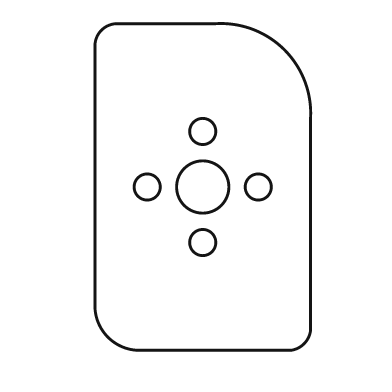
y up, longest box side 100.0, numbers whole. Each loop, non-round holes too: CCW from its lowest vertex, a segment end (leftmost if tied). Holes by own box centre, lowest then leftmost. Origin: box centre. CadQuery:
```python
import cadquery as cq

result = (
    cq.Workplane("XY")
    .moveTo(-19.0, -50.0)
    .lineTo(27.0, -50.0)
    .threePointArc((31.0, -48.0), (33.0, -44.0))
    .lineTo(33.0, 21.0)
    .threePointArc((25.0, 42.0), (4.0, 50.0))
    .lineTo(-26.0, 50.0)
    .threePointArc((-31.0, 48.0), (-33.0, 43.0))
    .lineTo(-33.0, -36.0)
    .threePointArc((-29.0, -46.0), (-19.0, -50.0))
    .close()
    .moveTo(0.0, -17.0)
    .circle(4.0)
    .moveTo(-17.0, 0.0)
    .circle(4.0)
    .moveTo(0.0, 0.0)
    .circle(8.0)
    .moveTo(17.0, 0.0)
    .circle(4.0)
    .moveTo(0.0, 17.0)
    .circle(4.0)
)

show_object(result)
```